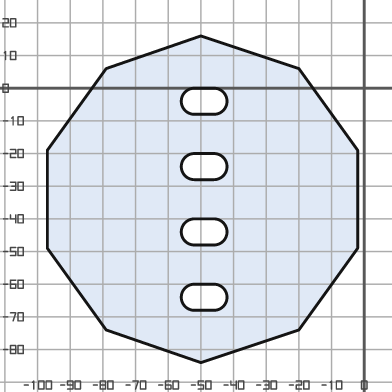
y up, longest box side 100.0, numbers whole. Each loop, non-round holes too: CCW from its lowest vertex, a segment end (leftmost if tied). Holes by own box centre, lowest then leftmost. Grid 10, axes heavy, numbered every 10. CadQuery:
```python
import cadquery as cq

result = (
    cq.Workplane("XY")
    .moveTo(-50.0, -84.0)
    .lineTo(-20.0, -74.0)
    .lineTo(-2.0, -49.0)
    .lineTo(-2.0, -19.0)
    .lineTo(-20.0, 6.0)
    .lineTo(-50.0, 16.0)
    .lineTo(-79.0, 6.0)
    .lineTo(-97.0, -19.0)
    .lineTo(-97.0, -49.0)
    .lineTo(-79.0, -74.0)
    .close()
    .moveTo(-52.0, -68.0)
    .lineTo(-46.0, -68.0)
    .threePointArc((-42.0, -64.0), (-46.0, -60.0))
    .lineTo(-52.0, -60.0)
    .threePointArc((-56.0, -64.0), (-52.0, -68.0))
    .close()
    .moveTo(-52.0, -48.0)
    .lineTo(-46.0, -48.0)
    .threePointArc((-42.0, -44.0), (-46.0, -40.0))
    .lineTo(-52.0, -40.0)
    .threePointArc((-56.0, -44.0), (-52.0, -48.0))
    .close()
    .moveTo(-52.0, -28.0)
    .lineTo(-46.0, -28.0)
    .threePointArc((-42.0, -24.0), (-46.0, -20.0))
    .lineTo(-52.0, -20.0)
    .threePointArc((-56.0, -24.0), (-52.0, -28.0))
    .close()
    .moveTo(-52.0, -8.0)
    .lineTo(-46.0, -8.0)
    .threePointArc((-42.0, -4.0), (-46.0, 0.0))
    .lineTo(-52.0, 0.0)
    .threePointArc((-56.0, -4.0), (-52.0, -8.0))
    .close()
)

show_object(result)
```